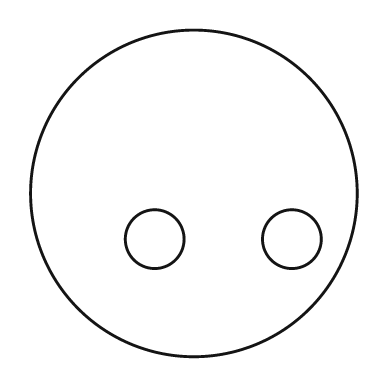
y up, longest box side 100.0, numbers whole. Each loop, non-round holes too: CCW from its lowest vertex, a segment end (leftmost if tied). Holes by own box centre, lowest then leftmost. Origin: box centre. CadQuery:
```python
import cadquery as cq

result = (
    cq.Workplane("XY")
    .moveTo(0.0, 0.0)
    .circle(50.0)
    .moveTo(-12.0, -14.0)
    .circle(9.0)
    .moveTo(30.0, -14.0)
    .circle(9.0)
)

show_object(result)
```